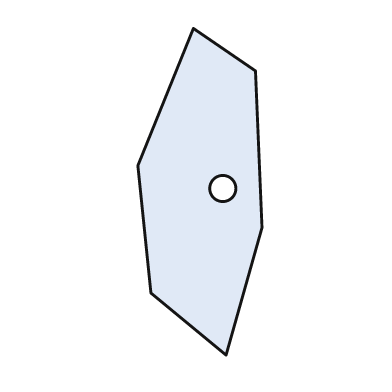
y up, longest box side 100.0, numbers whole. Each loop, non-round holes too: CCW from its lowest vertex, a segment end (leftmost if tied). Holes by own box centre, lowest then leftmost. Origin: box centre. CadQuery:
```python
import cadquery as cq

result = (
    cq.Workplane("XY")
    .moveTo(8.0, -50.0)
    .lineTo(19.0, -11.0)
    .lineTo(17.0, 37.0)
    .lineTo(-2.0, 50.0)
    .lineTo(-19.0, 8.0)
    .lineTo(-15.0, -31.0)
    .close()
    .moveTo(7.0, 1.0)
    .circle(4.0)
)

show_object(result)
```